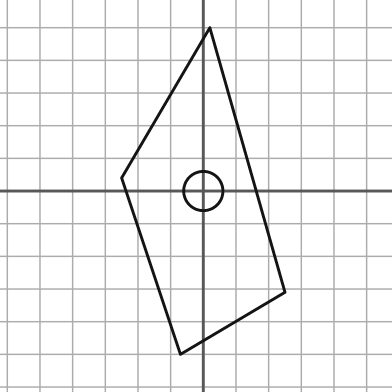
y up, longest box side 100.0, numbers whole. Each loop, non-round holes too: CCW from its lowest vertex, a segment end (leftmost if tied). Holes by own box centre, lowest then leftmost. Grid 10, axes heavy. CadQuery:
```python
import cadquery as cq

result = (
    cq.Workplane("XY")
    .moveTo(-7.0, -50.0)
    .lineTo(25.0, -31.0)
    .lineTo(2.0, 50.0)
    .lineTo(-25.0, 4.0)
    .close()
    .moveTo(0.0, 0.0)
    .circle(6.0)
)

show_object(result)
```